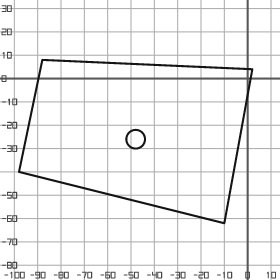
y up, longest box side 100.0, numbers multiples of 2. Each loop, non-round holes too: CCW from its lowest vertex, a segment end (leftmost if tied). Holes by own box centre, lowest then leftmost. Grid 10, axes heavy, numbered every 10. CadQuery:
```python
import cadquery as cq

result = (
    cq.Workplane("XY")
    .moveTo(-10.0, -62.0)
    .lineTo(2.0, 4.0)
    .lineTo(-88.0, 8.0)
    .lineTo(-98.0, -40.0)
    .close()
    .moveTo(-48.0, -26.0)
    .circle(4.0)
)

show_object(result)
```